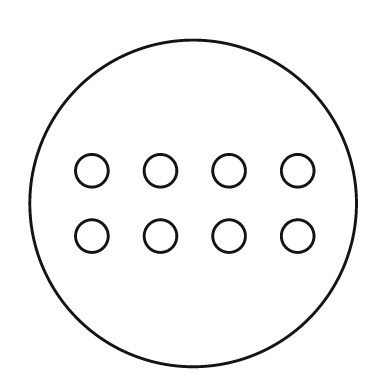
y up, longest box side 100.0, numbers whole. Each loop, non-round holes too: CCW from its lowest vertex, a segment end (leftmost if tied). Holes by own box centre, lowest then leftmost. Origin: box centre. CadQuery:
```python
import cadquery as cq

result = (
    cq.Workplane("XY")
    .moveTo(0.0, 0.0)
    .circle(50.0)
    .moveTo(-31.0, -10.0)
    .circle(5.0)
    .moveTo(-10.0, -10.0)
    .circle(5.0)
    .moveTo(11.0, -10.0)
    .circle(5.0)
    .moveTo(32.0, -10.0)
    .circle(5.0)
    .moveTo(-31.0, 10.0)
    .circle(5.0)
    .moveTo(-10.0, 10.0)
    .circle(5.0)
    .moveTo(11.0, 10.0)
    .circle(5.0)
    .moveTo(32.0, 10.0)
    .circle(5.0)
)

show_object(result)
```